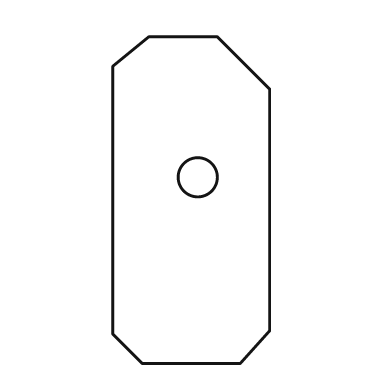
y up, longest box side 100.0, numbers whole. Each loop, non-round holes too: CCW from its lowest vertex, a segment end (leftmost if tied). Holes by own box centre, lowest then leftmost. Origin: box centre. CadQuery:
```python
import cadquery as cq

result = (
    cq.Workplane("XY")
    .moveTo(-15.0, -50.0)
    .lineTo(15.0, -50.0)
    .lineTo(24.0, -40.0)
    .lineTo(24.0, 34.0)
    .lineTo(8.0, 50.0)
    .lineTo(-13.0, 50.0)
    .lineTo(-24.0, 41.0)
    .lineTo(-24.0, -41.0)
    .close()
    .moveTo(2.0, 7.0)
    .circle(6.0)
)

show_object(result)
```